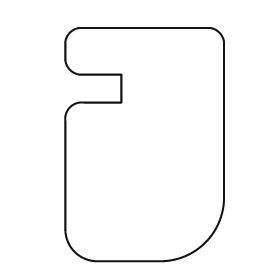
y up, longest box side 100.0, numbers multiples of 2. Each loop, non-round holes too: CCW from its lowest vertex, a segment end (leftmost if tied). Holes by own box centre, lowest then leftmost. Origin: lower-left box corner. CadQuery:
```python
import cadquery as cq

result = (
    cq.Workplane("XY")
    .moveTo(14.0, 0.0)
    .lineTo(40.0, 0.0)
    .threePointArc((60.0, 8.0), (68.0, 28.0))
    .lineTo(68.0, 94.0)
    .threePointArc((66.0, 98.0), (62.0, 100.0))
    .lineTo(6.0, 100.0)
    .threePointArc((2.0, 98.0), (0.0, 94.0))
    .lineTo(0.0, 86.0)
    .threePointArc((2.0, 82.0), (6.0, 80.0))
    .lineTo(24.0, 80.0)
    .lineTo(24.0, 68.0)
    .lineTo(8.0, 68.0)
    .threePointArc((2.0, 66.0), (0.0, 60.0))
    .lineTo(0.0, 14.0)
    .threePointArc((4.0, 4.0), (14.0, 0.0))
    .close()
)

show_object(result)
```